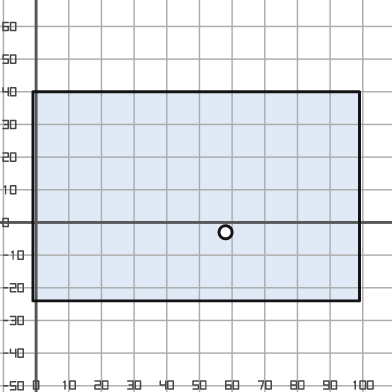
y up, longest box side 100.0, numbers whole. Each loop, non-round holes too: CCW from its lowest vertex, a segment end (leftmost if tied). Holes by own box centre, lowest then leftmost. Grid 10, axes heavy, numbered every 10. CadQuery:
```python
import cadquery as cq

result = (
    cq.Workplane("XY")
    .moveTo(-1.0, -24.0)
    .lineTo(99.0, -24.0)
    .lineTo(99.0, 40.0)
    .lineTo(-1.0, 40.0)
    .close()
    .moveTo(58.0, -3.0)
    .circle(2.0)
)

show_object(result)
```